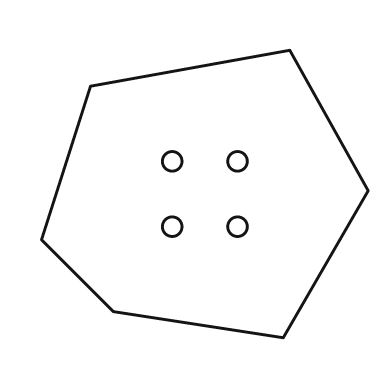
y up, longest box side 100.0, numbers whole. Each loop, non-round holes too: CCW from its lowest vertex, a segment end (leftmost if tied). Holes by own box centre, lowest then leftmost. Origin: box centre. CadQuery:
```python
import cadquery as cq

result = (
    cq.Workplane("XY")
    .moveTo(24.0, -44.0)
    .lineTo(50.0, 1.0)
    .lineTo(26.0, 44.0)
    .lineTo(-35.0, 33.0)
    .lineTo(-50.0, -14.0)
    .lineTo(-28.0, -36.0)
    .close()
    .moveTo(-10.0, -10.0)
    .circle(3.0)
    .moveTo(10.0, -10.0)
    .circle(3.0)
    .moveTo(-10.0, 10.0)
    .circle(3.0)
    .moveTo(10.0, 10.0)
    .circle(3.0)
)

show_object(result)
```